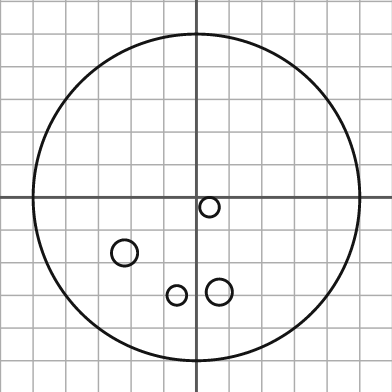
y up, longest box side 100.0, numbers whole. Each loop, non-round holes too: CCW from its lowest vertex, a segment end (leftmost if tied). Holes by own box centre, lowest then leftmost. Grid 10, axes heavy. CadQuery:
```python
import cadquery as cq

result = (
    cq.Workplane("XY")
    .moveTo(0.0, 0.0)
    .circle(50.0)
    .moveTo(-6.0, -30.0)
    .circle(3.0)
    .moveTo(7.0, -29.0)
    .circle(4.0)
    .moveTo(-22.0, -17.0)
    .circle(4.0)
    .moveTo(4.0, -3.0)
    .circle(3.0)
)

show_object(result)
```